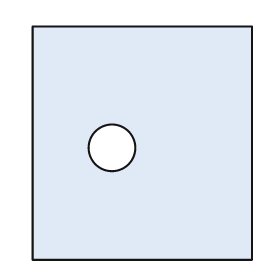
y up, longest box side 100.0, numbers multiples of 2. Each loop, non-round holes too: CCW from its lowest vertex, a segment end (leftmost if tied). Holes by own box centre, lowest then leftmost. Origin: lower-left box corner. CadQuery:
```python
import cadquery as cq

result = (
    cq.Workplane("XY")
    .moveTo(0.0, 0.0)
    .lineTo(94.0, 0.0)
    .lineTo(94.0, 100.0)
    .lineTo(0.0, 100.0)
    .close()
    .moveTo(34.0, 48.0)
    .circle(10.0)
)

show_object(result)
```